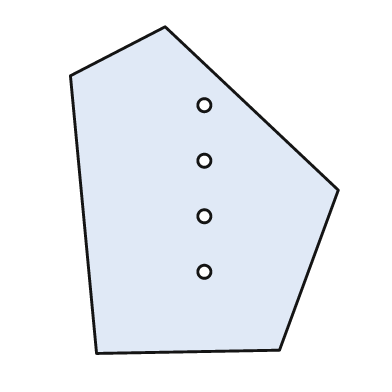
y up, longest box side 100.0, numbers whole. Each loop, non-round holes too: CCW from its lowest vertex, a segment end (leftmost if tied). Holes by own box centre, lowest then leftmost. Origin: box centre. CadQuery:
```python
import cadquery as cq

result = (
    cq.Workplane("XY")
    .moveTo(-33.0, -50.0)
    .lineTo(23.0, -49.0)
    .lineTo(41.0, 0.0)
    .lineTo(-12.0, 50.0)
    .lineTo(-41.0, 35.0)
    .close()
    .moveTo(0.0, -25.0)
    .circle(2.0)
    .moveTo(0.0, -8.0)
    .circle(2.0)
    .moveTo(0.0, 9.0)
    .circle(2.0)
    .moveTo(0.0, 26.0)
    .circle(2.0)
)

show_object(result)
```